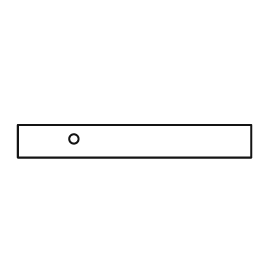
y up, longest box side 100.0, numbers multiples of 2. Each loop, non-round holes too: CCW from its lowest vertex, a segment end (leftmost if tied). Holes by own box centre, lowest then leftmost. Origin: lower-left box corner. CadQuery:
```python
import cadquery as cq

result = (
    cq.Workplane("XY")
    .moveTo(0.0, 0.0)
    .lineTo(100.0, 0.0)
    .lineTo(100.0, 14.0)
    .lineTo(0.0, 14.0)
    .close()
    .moveTo(24.0, 8.0)
    .circle(2.0)
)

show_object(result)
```